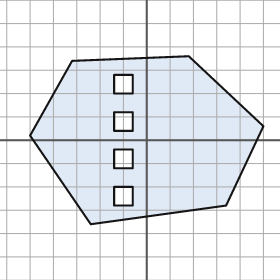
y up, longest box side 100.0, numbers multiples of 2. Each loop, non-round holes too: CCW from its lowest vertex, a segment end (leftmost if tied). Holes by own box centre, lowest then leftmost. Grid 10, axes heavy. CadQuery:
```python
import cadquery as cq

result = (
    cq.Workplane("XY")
    .moveTo(-24.0, -36.0)
    .lineTo(34.0, -28.0)
    .lineTo(50.0, 6.0)
    .lineTo(18.0, 36.0)
    .lineTo(-32.0, 34.0)
    .lineTo(-50.0, 2.0)
    .close()
    .moveTo(-14.0, -28.0)
    .lineTo(-6.0, -28.0)
    .lineTo(-6.0, -20.0)
    .lineTo(-14.0, -20.0)
    .close()
    .moveTo(-14.0, -12.0)
    .lineTo(-6.0, -12.0)
    .lineTo(-6.0, -4.0)
    .lineTo(-14.0, -4.0)
    .close()
    .moveTo(-14.0, 4.0)
    .lineTo(-6.0, 4.0)
    .lineTo(-6.0, 12.0)
    .lineTo(-14.0, 12.0)
    .close()
    .moveTo(-14.0, 20.0)
    .lineTo(-6.0, 20.0)
    .lineTo(-6.0, 28.0)
    .lineTo(-14.0, 28.0)
    .close()
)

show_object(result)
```